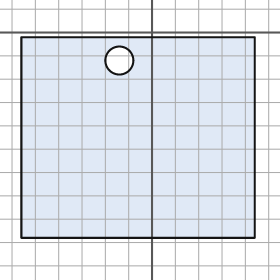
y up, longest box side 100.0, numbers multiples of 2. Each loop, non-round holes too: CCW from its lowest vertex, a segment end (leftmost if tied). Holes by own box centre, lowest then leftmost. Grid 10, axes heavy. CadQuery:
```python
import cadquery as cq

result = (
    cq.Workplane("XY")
    .moveTo(-56.0, -88.0)
    .lineTo(44.0, -88.0)
    .lineTo(44.0, -2.0)
    .lineTo(-56.0, -2.0)
    .close()
    .moveTo(-14.0, -12.0)
    .circle(6.0)
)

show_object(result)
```